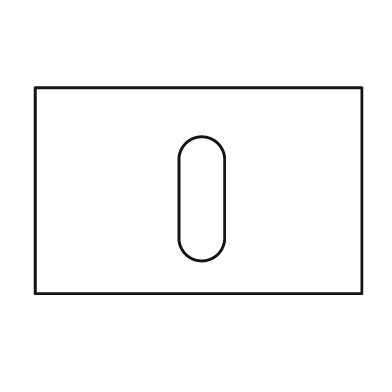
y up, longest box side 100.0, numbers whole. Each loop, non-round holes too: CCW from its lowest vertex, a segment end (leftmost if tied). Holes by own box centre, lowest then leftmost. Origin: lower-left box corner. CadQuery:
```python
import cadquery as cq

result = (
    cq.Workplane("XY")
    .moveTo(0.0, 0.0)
    .lineTo(100.0, 0.0)
    .lineTo(100.0, 63.0)
    .lineTo(0.0, 63.0)
    .close()
    .moveTo(44.0, 17.0)
    .threePointArc((51.0, 10.0), (58.0, 17.0))
    .lineTo(58.0, 41.0)
    .threePointArc((51.0, 48.0), (44.0, 41.0))
    .close()
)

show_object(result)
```